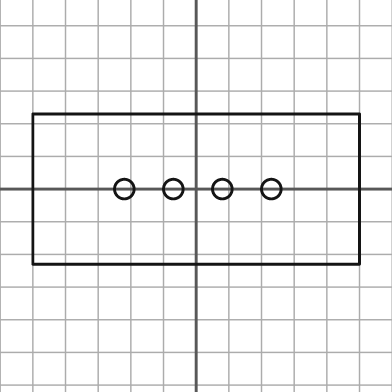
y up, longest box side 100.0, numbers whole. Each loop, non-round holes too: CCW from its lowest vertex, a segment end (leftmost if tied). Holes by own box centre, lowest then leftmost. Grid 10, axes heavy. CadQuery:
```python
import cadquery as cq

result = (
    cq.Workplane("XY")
    .moveTo(-50.0, -23.0)
    .lineTo(50.0, -23.0)
    .lineTo(50.0, 23.0)
    .lineTo(-50.0, 23.0)
    .close()
    .moveTo(-22.0, 0.0)
    .circle(3.0)
    .moveTo(-7.0, 0.0)
    .circle(3.0)
    .moveTo(8.0, 0.0)
    .circle(3.0)
    .moveTo(23.0, 0.0)
    .circle(3.0)
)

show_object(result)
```